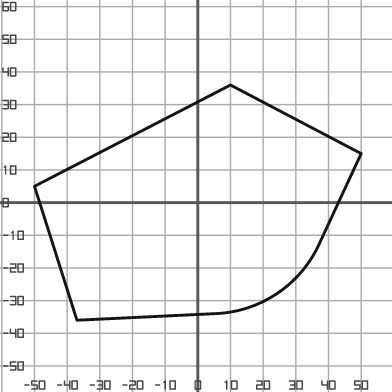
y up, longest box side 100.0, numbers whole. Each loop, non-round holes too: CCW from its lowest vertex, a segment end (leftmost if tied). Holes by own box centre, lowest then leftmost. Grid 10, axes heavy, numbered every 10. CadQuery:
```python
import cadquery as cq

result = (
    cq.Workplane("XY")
    .moveTo(-37.0, -36.0)
    .lineTo(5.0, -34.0)
    .threePointArc((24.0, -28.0), (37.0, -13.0))
    .lineTo(50.0, 15.0)
    .lineTo(10.0, 36.0)
    .lineTo(-50.0, 5.0)
    .close()
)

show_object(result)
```